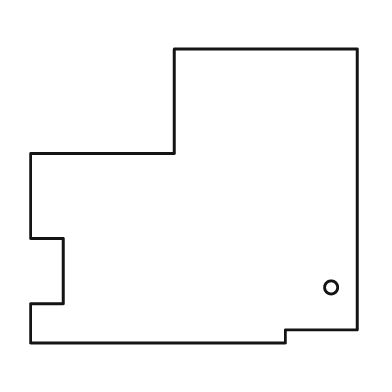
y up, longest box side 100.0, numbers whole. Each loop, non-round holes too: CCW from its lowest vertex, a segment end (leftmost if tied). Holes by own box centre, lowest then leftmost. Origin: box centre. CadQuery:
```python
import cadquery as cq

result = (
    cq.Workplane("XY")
    .moveTo(-50.0, -45.0)
    .lineTo(28.0, -45.0)
    .lineTo(28.0, -41.0)
    .lineTo(50.0, -41.0)
    .lineTo(50.0, 45.0)
    .lineTo(-6.0, 45.0)
    .lineTo(-6.0, 13.0)
    .lineTo(-50.0, 13.0)
    .lineTo(-50.0, -13.0)
    .lineTo(-40.0, -13.0)
    .lineTo(-40.0, -33.0)
    .lineTo(-50.0, -33.0)
    .close()
    .moveTo(42.0, -28.0)
    .circle(2.0)
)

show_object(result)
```